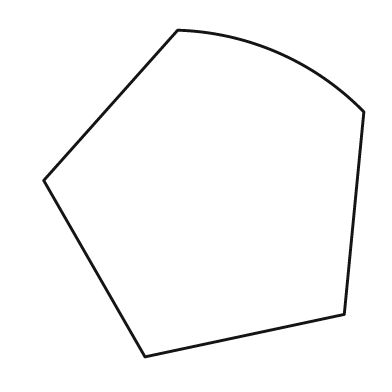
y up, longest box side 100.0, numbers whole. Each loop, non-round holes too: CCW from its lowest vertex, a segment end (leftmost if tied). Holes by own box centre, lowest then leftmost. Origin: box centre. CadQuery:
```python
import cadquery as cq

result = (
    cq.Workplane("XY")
    .moveTo(-18.0, -50.0)
    .lineTo(43.0, -37.0)
    .lineTo(49.0, 25.0)
    .threePointArc((23.0, 43.0), (-8.0, 50.0))
    .lineTo(-49.0, 4.0)
    .close()
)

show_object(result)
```